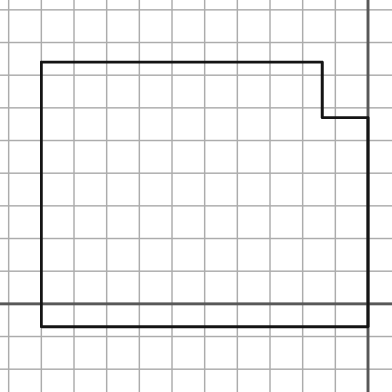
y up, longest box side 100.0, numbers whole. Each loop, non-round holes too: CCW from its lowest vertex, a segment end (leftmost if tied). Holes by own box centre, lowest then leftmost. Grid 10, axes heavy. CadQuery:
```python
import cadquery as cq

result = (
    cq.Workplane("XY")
    .moveTo(-100.0, -7.0)
    .lineTo(0.0, -7.0)
    .lineTo(0.0, 57.0)
    .lineTo(-14.0, 57.0)
    .lineTo(-14.0, 74.0)
    .lineTo(-100.0, 74.0)
    .close()
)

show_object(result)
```